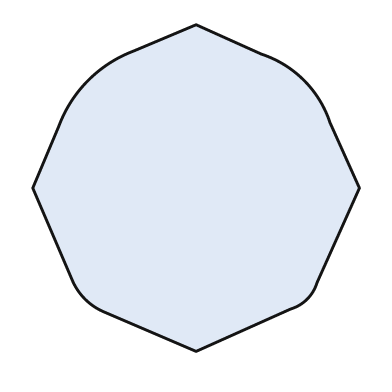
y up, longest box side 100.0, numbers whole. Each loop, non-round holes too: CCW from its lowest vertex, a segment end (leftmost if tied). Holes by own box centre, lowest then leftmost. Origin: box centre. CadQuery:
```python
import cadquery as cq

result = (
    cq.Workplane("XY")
    .moveTo(0.0, -50.0)
    .lineTo(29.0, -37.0)
    .threePointArc((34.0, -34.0), (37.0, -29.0))
    .lineTo(50.0, 0.0)
    .lineTo(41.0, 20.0)
    .threePointArc((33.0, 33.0), (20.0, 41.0))
    .lineTo(0.0, 50.0)
    .lineTo(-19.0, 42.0)
    .threePointArc((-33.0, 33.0), (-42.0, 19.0))
    .lineTo(-50.0, 0.0)
    .lineTo(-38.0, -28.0)
    .threePointArc((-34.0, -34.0), (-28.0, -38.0))
    .close()
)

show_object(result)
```